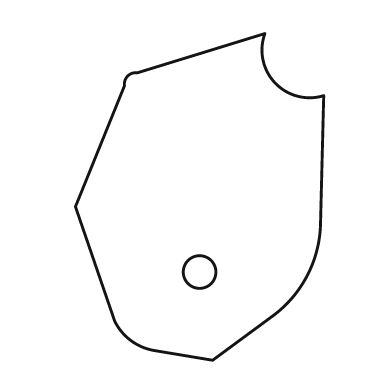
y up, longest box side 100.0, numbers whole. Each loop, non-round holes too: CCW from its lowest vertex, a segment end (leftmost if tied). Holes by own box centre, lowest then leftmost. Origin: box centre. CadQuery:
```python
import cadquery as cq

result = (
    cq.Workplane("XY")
    .moveTo(4.0, -50.0)
    .lineTo(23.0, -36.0)
    .threePointArc((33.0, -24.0), (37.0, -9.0))
    .lineTo(38.0, 31.0)
    .threePointArc((23.0, 35.0), (20.0, 50.0))
    .lineTo(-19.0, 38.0)
    .threePointArc((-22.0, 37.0), (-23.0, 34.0))
    .lineTo(-38.0, -3.0)
    .lineTo(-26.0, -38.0)
    .threePointArc((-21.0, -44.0), (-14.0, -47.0))
    .close()
    .moveTo(0.0, -23.0)
    .circle(5.0)
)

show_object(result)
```